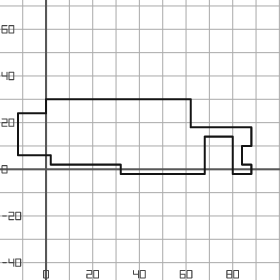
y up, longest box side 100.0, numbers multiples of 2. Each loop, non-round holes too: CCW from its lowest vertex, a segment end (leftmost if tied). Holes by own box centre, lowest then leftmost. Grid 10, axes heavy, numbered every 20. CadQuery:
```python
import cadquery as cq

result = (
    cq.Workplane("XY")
    .moveTo(32.0, -2.0)
    .lineTo(68.0, -2.0)
    .lineTo(68.0, 14.0)
    .lineTo(80.0, 14.0)
    .lineTo(80.0, -2.0)
    .lineTo(88.0, -2.0)
    .lineTo(88.0, 2.0)
    .lineTo(84.0, 2.0)
    .lineTo(84.0, 10.0)
    .lineTo(88.0, 10.0)
    .lineTo(88.0, 18.0)
    .lineTo(62.0, 18.0)
    .lineTo(62.0, 30.0)
    .lineTo(0.0, 30.0)
    .lineTo(0.0, 24.0)
    .lineTo(-12.0, 24.0)
    .lineTo(-12.0, 6.0)
    .lineTo(2.0, 6.0)
    .lineTo(2.0, 2.0)
    .lineTo(32.0, 2.0)
    .close()
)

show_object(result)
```